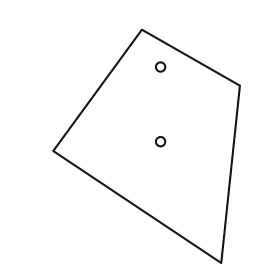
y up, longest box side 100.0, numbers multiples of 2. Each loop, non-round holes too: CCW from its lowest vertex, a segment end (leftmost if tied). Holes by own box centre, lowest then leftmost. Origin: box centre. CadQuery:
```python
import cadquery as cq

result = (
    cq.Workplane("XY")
    .moveTo(32.0, -50.0)
    .lineTo(40.0, 26.0)
    .lineTo(-2.0, 50.0)
    .lineTo(-40.0, -2.0)
    .close()
    .moveTo(6.0, 2.0)
    .circle(2.0)
    .moveTo(6.0, 34.0)
    .circle(2.0)
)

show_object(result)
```